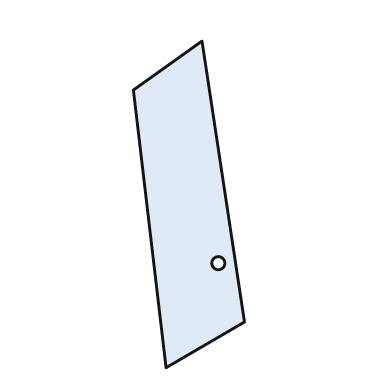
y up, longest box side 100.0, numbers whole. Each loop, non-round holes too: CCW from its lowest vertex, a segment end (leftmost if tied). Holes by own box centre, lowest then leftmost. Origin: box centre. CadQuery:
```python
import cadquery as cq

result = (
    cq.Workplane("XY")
    .moveTo(-7.0, -50.0)
    .lineTo(17.0, -36.0)
    .lineTo(4.0, 50.0)
    .lineTo(-17.0, 35.0)
    .close()
    .moveTo(9.0, -18.0)
    .circle(2.0)
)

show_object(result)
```